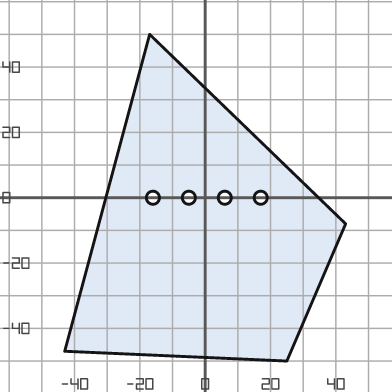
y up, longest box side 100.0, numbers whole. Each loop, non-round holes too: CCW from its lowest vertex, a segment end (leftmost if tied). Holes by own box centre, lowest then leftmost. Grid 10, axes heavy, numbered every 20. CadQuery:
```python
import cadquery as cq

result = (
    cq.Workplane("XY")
    .moveTo(25.0, -50.0)
    .lineTo(43.0, -8.0)
    .lineTo(-17.0, 50.0)
    .lineTo(-43.0, -47.0)
    .close()
    .moveTo(-16.0, 0.0)
    .circle(2.0)
    .moveTo(-5.0, 0.0)
    .circle(2.0)
    .moveTo(6.0, 0.0)
    .circle(2.0)
    .moveTo(17.0, 0.0)
    .circle(2.0)
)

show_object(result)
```